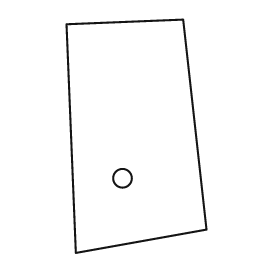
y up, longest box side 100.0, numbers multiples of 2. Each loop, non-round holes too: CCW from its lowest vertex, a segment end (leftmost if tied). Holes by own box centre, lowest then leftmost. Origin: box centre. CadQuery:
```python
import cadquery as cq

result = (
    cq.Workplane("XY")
    .moveTo(-26.0, -50.0)
    .lineTo(30.0, -40.0)
    .lineTo(20.0, 50.0)
    .lineTo(-30.0, 48.0)
    .close()
    .moveTo(-6.0, -18.0)
    .circle(4.0)
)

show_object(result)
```